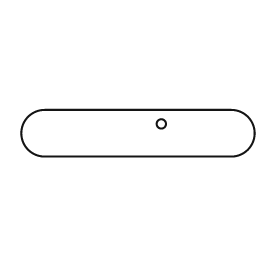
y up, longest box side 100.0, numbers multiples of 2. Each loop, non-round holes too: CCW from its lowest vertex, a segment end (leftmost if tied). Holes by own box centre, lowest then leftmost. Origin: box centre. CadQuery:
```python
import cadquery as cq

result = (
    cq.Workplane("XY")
    .moveTo(-40.0, -10.0)
    .lineTo(40.0, -10.0)
    .threePointArc((50.0, 0.0), (40.0, 10.0))
    .lineTo(-40.0, 10.0)
    .threePointArc((-50.0, 0.0), (-40.0, -10.0))
    .close()
    .moveTo(10.0, 4.0)
    .circle(2.0)
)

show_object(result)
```